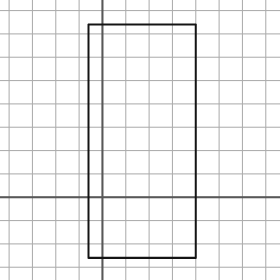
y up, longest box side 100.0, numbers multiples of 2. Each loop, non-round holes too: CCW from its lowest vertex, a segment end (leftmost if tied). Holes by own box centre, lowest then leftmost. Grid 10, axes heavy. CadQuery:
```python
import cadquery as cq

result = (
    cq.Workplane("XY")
    .moveTo(-6.0, -26.0)
    .lineTo(40.0, -26.0)
    .lineTo(40.0, 74.0)
    .lineTo(-6.0, 74.0)
    .close()
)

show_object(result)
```